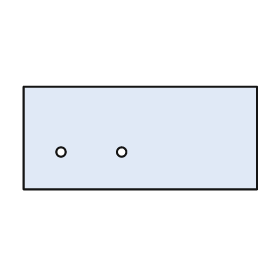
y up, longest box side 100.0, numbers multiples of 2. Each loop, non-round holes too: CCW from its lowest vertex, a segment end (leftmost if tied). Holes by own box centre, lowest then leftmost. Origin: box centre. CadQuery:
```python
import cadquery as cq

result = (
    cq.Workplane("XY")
    .moveTo(-50.0, -22.0)
    .lineTo(50.0, -22.0)
    .lineTo(50.0, 22.0)
    .lineTo(-50.0, 22.0)
    .close()
    .moveTo(-34.0, -6.0)
    .circle(2.0)
    .moveTo(-8.0, -6.0)
    .circle(2.0)
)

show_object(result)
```